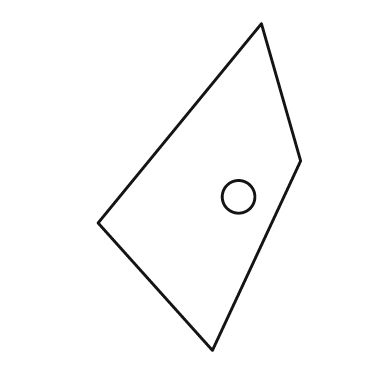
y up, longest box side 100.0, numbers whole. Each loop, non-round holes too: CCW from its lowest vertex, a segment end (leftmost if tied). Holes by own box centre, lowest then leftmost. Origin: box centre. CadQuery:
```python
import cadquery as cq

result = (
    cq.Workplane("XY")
    .moveTo(4.0, -50.0)
    .lineTo(31.0, 8.0)
    .lineTo(19.0, 50.0)
    .lineTo(-31.0, -11.0)
    .close()
    .moveTo(12.0, -3.0)
    .circle(5.0)
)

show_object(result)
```